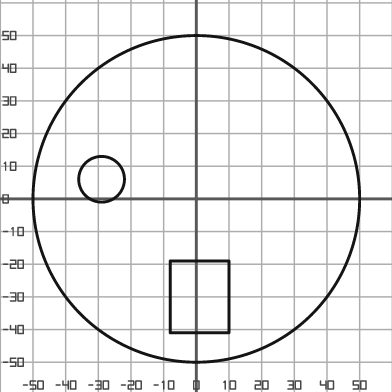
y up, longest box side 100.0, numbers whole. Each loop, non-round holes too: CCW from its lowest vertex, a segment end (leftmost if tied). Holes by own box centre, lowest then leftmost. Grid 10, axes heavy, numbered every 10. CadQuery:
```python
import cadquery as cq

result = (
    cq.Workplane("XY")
    .moveTo(0.0, 0.0)
    .circle(50.0)
    .moveTo(-8.0, -41.0)
    .lineTo(10.0, -41.0)
    .lineTo(10.0, -19.0)
    .lineTo(-8.0, -19.0)
    .close()
    .moveTo(-29.0, 6.0)
    .circle(7.0)
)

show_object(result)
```